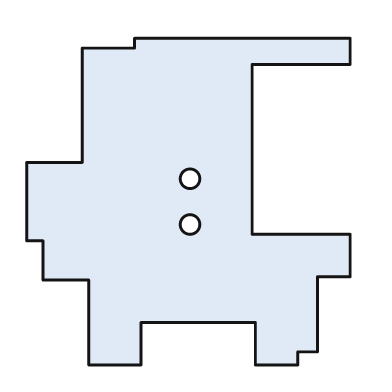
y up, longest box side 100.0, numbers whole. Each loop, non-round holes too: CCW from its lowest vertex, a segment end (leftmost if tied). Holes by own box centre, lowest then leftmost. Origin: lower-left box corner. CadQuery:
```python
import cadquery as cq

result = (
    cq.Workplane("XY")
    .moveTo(19.0, 0.0)
    .lineTo(35.0, 0.0)
    .lineTo(35.0, 13.0)
    .lineTo(70.0, 13.0)
    .lineTo(70.0, 0.0)
    .lineTo(83.0, 0.0)
    .lineTo(83.0, 4.0)
    .lineTo(89.0, 4.0)
    .lineTo(89.0, 27.0)
    .lineTo(99.0, 27.0)
    .lineTo(99.0, 40.0)
    .lineTo(69.0, 40.0)
    .lineTo(69.0, 92.0)
    .lineTo(99.0, 92.0)
    .lineTo(99.0, 100.0)
    .lineTo(33.0, 100.0)
    .lineTo(33.0, 97.0)
    .lineTo(17.0, 97.0)
    .lineTo(17.0, 62.0)
    .lineTo(0.0, 62.0)
    .lineTo(0.0, 38.0)
    .lineTo(5.0, 38.0)
    .lineTo(5.0, 26.0)
    .lineTo(19.0, 26.0)
    .close()
    .moveTo(50.0, 43.0)
    .circle(3.0)
    .moveTo(50.0, 57.0)
    .circle(3.0)
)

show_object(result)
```